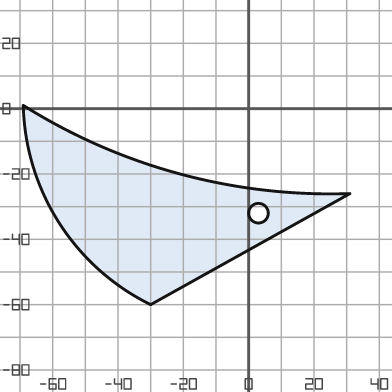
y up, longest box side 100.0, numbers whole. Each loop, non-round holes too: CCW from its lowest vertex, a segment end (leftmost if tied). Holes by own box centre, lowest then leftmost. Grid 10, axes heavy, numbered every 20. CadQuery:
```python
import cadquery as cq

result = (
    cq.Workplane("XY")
    .moveTo(-30.0, -60.0)
    .lineTo(31.0, -26.0)
    .threePointArc((-21.0, -20.0), (-69.0, 1.0))
    .threePointArc((-58.0, -35.0), (-30.0, -60.0))
    .close()
    .moveTo(3.0, -32.0)
    .circle(3.0)
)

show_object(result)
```